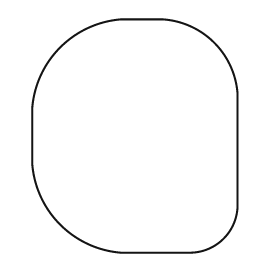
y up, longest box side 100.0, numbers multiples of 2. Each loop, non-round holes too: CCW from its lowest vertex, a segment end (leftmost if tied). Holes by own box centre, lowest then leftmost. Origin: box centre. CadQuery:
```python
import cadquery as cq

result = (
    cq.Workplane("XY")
    .moveTo(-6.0, -50.0)
    .lineTo(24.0, -50.0)
    .threePointArc((38.0, -44.0), (44.0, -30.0))
    .lineTo(44.0, 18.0)
    .threePointArc((34.0, 40.0), (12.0, 50.0))
    .lineTo(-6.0, 50.0)
    .threePointArc((-32.0, 38.0), (-44.0, 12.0))
    .lineTo(-44.0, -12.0)
    .threePointArc((-32.0, -38.0), (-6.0, -50.0))
    .close()
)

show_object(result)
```